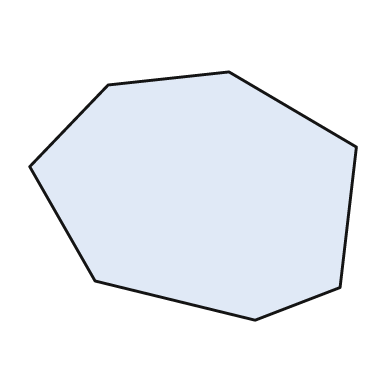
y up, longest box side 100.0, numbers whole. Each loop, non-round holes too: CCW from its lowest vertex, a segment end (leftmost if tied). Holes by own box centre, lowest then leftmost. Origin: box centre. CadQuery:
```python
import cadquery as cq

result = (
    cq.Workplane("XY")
    .moveTo(19.0, -38.0)
    .lineTo(45.0, -28.0)
    .lineTo(50.0, 15.0)
    .lineTo(11.0, 38.0)
    .lineTo(-26.0, 34.0)
    .lineTo(-50.0, 9.0)
    .lineTo(-30.0, -26.0)
    .close()
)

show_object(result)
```